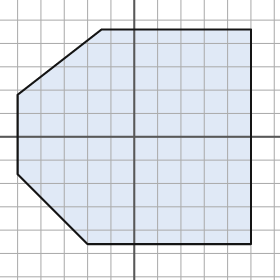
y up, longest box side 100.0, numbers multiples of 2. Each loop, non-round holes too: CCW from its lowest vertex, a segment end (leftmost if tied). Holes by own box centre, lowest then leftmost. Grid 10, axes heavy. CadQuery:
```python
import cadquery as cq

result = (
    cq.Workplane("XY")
    .moveTo(-20.0, -46.0)
    .lineTo(50.0, -46.0)
    .lineTo(50.0, 46.0)
    .lineTo(-14.0, 46.0)
    .lineTo(-50.0, 18.0)
    .lineTo(-50.0, -16.0)
    .close()
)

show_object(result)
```